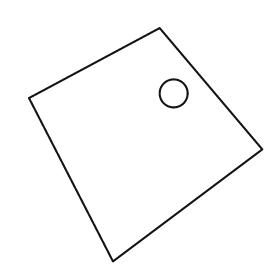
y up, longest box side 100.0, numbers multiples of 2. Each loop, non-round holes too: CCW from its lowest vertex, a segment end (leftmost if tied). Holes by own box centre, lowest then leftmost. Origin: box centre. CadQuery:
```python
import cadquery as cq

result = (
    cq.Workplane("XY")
    .moveTo(-14.0, -50.0)
    .lineTo(50.0, -2.0)
    .lineTo(6.0, 50.0)
    .lineTo(-50.0, 20.0)
    .close()
    .moveTo(12.0, 22.0)
    .circle(6.0)
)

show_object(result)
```